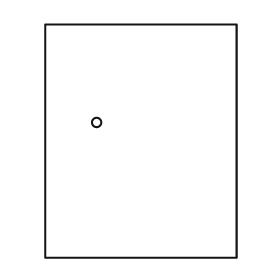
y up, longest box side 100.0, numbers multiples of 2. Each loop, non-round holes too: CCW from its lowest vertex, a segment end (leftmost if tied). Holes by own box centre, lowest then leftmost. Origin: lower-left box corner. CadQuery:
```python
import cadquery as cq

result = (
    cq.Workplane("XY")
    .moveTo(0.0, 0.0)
    .lineTo(82.0, 0.0)
    .lineTo(82.0, 100.0)
    .lineTo(0.0, 100.0)
    .close()
    .moveTo(22.0, 58.0)
    .circle(2.0)
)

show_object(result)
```